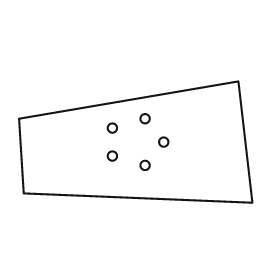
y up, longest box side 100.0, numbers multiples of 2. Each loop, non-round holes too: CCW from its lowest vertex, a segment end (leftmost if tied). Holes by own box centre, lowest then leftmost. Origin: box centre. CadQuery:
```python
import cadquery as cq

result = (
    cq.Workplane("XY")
    .moveTo(50.0, -26.0)
    .lineTo(44.0, 26.0)
    .lineTo(-50.0, 10.0)
    .lineTo(-48.0, -22.0)
    .close()
    .moveTo(4.0, -10.0)
    .circle(2.0)
    .moveTo(-10.0, -6.0)
    .circle(2.0)
    .moveTo(12.0, 0.0)
    .circle(2.0)
    .moveTo(-10.0, 6.0)
    .circle(2.0)
    .moveTo(4.0, 10.0)
    .circle(2.0)
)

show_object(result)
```